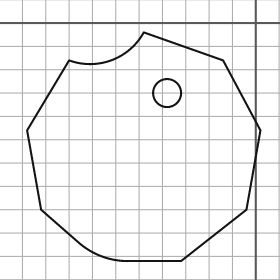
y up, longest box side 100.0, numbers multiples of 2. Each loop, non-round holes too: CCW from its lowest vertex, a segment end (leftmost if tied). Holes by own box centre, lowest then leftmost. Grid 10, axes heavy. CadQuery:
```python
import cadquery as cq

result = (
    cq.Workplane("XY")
    .moveTo(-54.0, -102.0)
    .lineTo(-32.0, -102.0)
    .lineTo(-4.0, -80.0)
    .lineTo(2.0, -46.0)
    .lineTo(-14.0, -16.0)
    .lineTo(-48.0, -4.0)
    .threePointArc((-62.0, -16.0), (-80.0, -16.0))
    .lineTo(-98.0, -46.0)
    .lineTo(-92.0, -80.0)
    .lineTo(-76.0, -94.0)
    .threePointArc((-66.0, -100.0), (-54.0, -102.0))
    .close()
    .moveTo(-38.0, -30.0)
    .circle(6.0)
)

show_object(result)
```